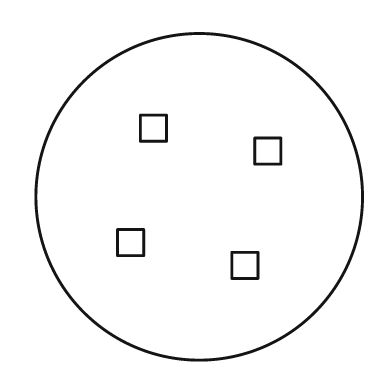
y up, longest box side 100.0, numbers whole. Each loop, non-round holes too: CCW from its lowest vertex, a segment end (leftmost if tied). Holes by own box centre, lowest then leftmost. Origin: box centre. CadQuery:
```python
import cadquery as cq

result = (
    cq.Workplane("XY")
    .moveTo(0.0, 0.0)
    .circle(50.0)
    .moveTo(10.0, -25.0)
    .lineTo(18.0, -25.0)
    .lineTo(18.0, -17.0)
    .lineTo(10.0, -17.0)
    .close()
    .moveTo(-25.0, -18.0)
    .lineTo(-17.0, -18.0)
    .lineTo(-17.0, -10.0)
    .lineTo(-25.0, -10.0)
    .close()
    .moveTo(17.0, 10.0)
    .lineTo(25.0, 10.0)
    .lineTo(25.0, 18.0)
    .lineTo(17.0, 18.0)
    .close()
    .moveTo(-18.0, 17.0)
    .lineTo(-10.0, 17.0)
    .lineTo(-10.0, 25.0)
    .lineTo(-18.0, 25.0)
    .close()
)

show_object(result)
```